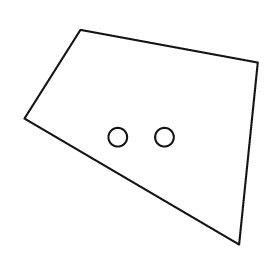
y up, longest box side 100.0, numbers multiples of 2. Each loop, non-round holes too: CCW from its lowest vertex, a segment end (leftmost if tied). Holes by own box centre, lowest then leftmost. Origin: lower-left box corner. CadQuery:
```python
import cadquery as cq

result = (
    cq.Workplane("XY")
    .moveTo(92.0, 0.0)
    .lineTo(100.0, 78.0)
    .lineTo(24.0, 92.0)
    .lineTo(0.0, 54.0)
    .close()
    .moveTo(40.0, 46.0)
    .circle(4.0)
    .moveTo(60.0, 46.0)
    .circle(4.0)
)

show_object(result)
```